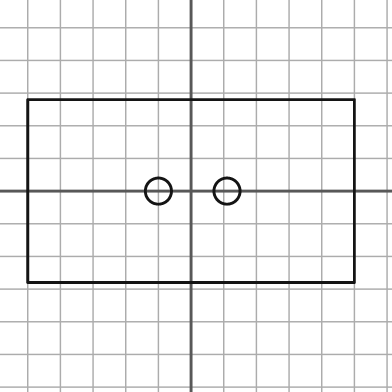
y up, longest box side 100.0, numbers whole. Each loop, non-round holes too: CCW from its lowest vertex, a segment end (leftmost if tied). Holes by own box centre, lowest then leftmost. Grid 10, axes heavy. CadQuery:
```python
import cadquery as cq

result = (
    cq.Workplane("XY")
    .moveTo(-50.0, -28.0)
    .lineTo(50.0, -28.0)
    .lineTo(50.0, 28.0)
    .lineTo(-50.0, 28.0)
    .close()
    .moveTo(-10.0, 0.0)
    .circle(4.0)
    .moveTo(11.0, 0.0)
    .circle(4.0)
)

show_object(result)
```